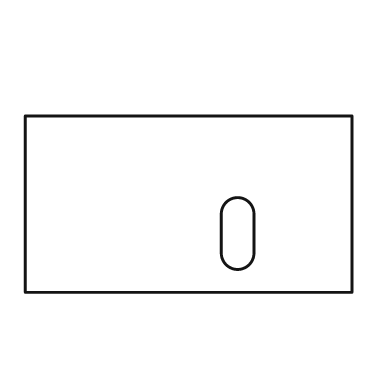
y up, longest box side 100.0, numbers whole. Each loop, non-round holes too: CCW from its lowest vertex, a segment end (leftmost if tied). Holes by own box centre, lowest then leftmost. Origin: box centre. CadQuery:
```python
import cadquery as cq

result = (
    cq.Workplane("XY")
    .moveTo(-50.0, -27.0)
    .lineTo(50.0, -27.0)
    .lineTo(50.0, 27.0)
    .lineTo(-50.0, 27.0)
    .close()
    .moveTo(10.0, -15.0)
    .threePointArc((15.0, -20.0), (20.0, -15.0))
    .lineTo(20.0, -3.0)
    .threePointArc((15.0, 2.0), (10.0, -3.0))
    .close()
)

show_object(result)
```